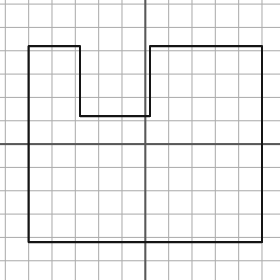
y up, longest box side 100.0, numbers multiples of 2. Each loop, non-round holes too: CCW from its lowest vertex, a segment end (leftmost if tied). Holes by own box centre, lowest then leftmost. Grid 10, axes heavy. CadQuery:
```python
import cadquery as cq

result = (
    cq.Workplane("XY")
    .moveTo(-50.0, -42.0)
    .lineTo(50.0, -42.0)
    .lineTo(50.0, 42.0)
    .lineTo(2.0, 42.0)
    .lineTo(2.0, 12.0)
    .lineTo(-28.0, 12.0)
    .lineTo(-28.0, 42.0)
    .lineTo(-50.0, 42.0)
    .close()
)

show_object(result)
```